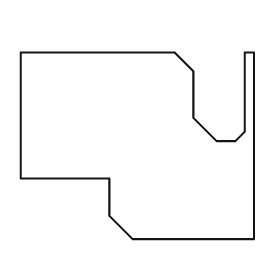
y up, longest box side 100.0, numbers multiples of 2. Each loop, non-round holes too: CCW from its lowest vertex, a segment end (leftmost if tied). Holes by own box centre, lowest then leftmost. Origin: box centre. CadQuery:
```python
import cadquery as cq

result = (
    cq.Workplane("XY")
    .moveTo(-2.0, -40.0)
    .lineTo(50.0, -40.0)
    .lineTo(50.0, 40.0)
    .lineTo(46.0, 40.0)
    .lineTo(46.0, 6.0)
    .lineTo(42.0, 2.0)
    .lineTo(34.0, 2.0)
    .lineTo(24.0, 12.0)
    .lineTo(24.0, 32.0)
    .lineTo(16.0, 40.0)
    .lineTo(-50.0, 40.0)
    .lineTo(-50.0, -14.0)
    .lineTo(-12.0, -14.0)
    .lineTo(-12.0, -30.0)
    .close()
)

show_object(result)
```